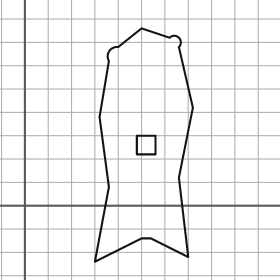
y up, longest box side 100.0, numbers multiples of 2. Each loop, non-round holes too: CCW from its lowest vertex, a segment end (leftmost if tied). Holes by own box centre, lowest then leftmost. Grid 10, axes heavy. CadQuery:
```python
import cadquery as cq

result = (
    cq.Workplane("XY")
    .moveTo(30.0, -24.0)
    .lineTo(50.0, -14.0)
    .lineTo(54.0, -14.0)
    .lineTo(70.0, -22.0)
    .lineTo(66.0, 12.0)
    .lineTo(72.0, 42.0)
    .lineTo(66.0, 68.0)
    .threePointArc((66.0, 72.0), (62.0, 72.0))
    .lineTo(50.0, 76.0)
    .lineTo(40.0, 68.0)
    .threePointArc((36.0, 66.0), (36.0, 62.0))
    .lineTo(32.0, 38.0)
    .lineTo(36.0, 8.0)
    .close()
    .moveTo(48.0, 22.0)
    .lineTo(56.0, 22.0)
    .lineTo(56.0, 30.0)
    .lineTo(48.0, 30.0)
    .close()
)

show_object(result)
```